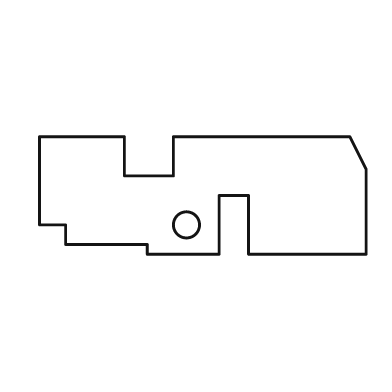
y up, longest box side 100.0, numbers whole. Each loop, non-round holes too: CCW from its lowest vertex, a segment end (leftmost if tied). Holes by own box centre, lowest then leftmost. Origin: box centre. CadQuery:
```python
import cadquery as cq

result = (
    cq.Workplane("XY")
    .moveTo(-17.0, -18.0)
    .lineTo(5.0, -18.0)
    .lineTo(5.0, 0.0)
    .lineTo(14.0, 0.0)
    .lineTo(14.0, -18.0)
    .lineTo(50.0, -18.0)
    .lineTo(50.0, 8.0)
    .lineTo(45.0, 18.0)
    .lineTo(-9.0, 18.0)
    .lineTo(-9.0, 6.0)
    .lineTo(-24.0, 6.0)
    .lineTo(-24.0, 18.0)
    .lineTo(-50.0, 18.0)
    .lineTo(-50.0, -9.0)
    .lineTo(-42.0, -9.0)
    .lineTo(-42.0, -15.0)
    .lineTo(-17.0, -15.0)
    .close()
    .moveTo(-5.0, -9.0)
    .circle(4.0)
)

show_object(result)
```